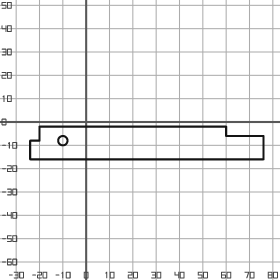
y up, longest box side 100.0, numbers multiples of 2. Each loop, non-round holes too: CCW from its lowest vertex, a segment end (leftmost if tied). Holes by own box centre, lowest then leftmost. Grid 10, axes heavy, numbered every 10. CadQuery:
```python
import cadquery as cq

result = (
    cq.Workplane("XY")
    .moveTo(-24.0, -16.0)
    .lineTo(76.0, -16.0)
    .lineTo(76.0, -6.0)
    .lineTo(60.0, -6.0)
    .lineTo(60.0, -2.0)
    .lineTo(-20.0, -2.0)
    .lineTo(-20.0, -8.0)
    .lineTo(-24.0, -8.0)
    .close()
    .moveTo(-10.0, -8.0)
    .circle(2.0)
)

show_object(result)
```